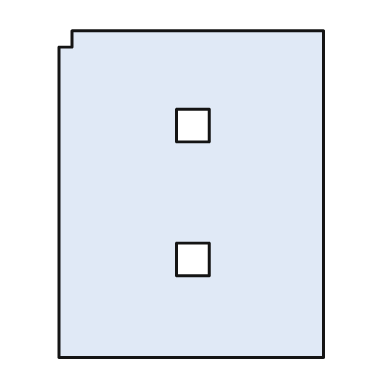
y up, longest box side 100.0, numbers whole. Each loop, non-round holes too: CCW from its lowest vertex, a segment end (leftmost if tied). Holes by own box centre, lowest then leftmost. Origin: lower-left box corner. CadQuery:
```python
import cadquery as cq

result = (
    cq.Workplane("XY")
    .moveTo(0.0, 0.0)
    .lineTo(81.0, 0.0)
    .lineTo(81.0, 100.0)
    .lineTo(4.0, 100.0)
    .lineTo(4.0, 95.0)
    .lineTo(0.0, 95.0)
    .close()
    .moveTo(36.0, 25.0)
    .lineTo(46.0, 25.0)
    .lineTo(46.0, 35.0)
    .lineTo(36.0, 35.0)
    .close()
    .moveTo(36.0, 66.0)
    .lineTo(46.0, 66.0)
    .lineTo(46.0, 76.0)
    .lineTo(36.0, 76.0)
    .close()
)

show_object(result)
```